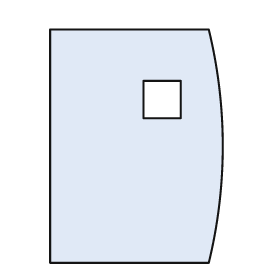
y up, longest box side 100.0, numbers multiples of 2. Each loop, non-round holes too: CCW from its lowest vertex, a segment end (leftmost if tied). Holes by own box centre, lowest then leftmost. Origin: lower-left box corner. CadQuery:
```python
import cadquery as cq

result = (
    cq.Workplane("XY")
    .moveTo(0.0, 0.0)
    .lineTo(68.0, 0.0)
    .threePointArc((74.0, 50.0), (68.0, 100.0))
    .lineTo(0.0, 100.0)
    .close()
    .moveTo(40.0, 62.0)
    .lineTo(56.0, 62.0)
    .lineTo(56.0, 78.0)
    .lineTo(40.0, 78.0)
    .close()
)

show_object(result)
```